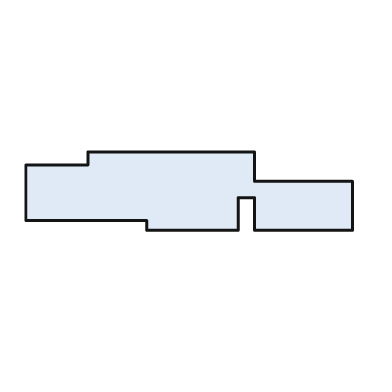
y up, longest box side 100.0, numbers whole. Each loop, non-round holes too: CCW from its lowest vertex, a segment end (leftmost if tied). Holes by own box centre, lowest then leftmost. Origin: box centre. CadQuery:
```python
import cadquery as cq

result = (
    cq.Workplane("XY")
    .moveTo(-13.0, -12.0)
    .lineTo(15.0, -12.0)
    .lineTo(15.0, -2.0)
    .lineTo(20.0, -2.0)
    .lineTo(20.0, -12.0)
    .lineTo(50.0, -12.0)
    .lineTo(50.0, 3.0)
    .lineTo(20.0, 3.0)
    .lineTo(20.0, 12.0)
    .lineTo(-31.0, 12.0)
    .lineTo(-31.0, 8.0)
    .lineTo(-50.0, 8.0)
    .lineTo(-50.0, -9.0)
    .lineTo(-13.0, -9.0)
    .close()
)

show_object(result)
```